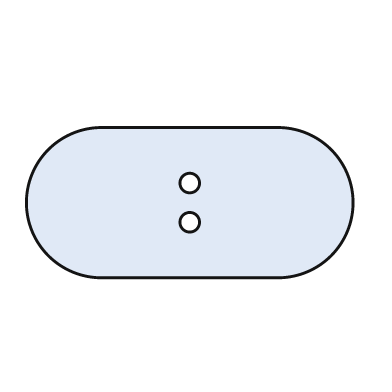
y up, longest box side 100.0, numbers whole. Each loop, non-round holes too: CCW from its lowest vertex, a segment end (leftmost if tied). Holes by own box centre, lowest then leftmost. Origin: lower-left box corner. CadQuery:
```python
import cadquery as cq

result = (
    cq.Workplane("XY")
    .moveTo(23.0, 0.0)
    .lineTo(77.0, 0.0)
    .threePointArc((100.0, 23.0), (77.0, 46.0))
    .lineTo(23.0, 46.0)
    .threePointArc((0.0, 23.0), (23.0, 0.0))
    .close()
    .moveTo(50.0, 17.0)
    .circle(3.0)
    .moveTo(50.0, 29.0)
    .circle(3.0)
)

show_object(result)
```